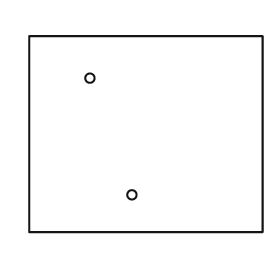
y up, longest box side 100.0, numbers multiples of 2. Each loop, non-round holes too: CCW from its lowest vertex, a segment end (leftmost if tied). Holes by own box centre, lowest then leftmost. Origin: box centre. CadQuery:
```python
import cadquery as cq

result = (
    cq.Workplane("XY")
    .moveTo(-50.0, -42.0)
    .lineTo(50.0, -42.0)
    .lineTo(50.0, 42.0)
    .lineTo(-50.0, 42.0)
    .close()
    .moveTo(-6.0, -26.0)
    .circle(2.0)
    .moveTo(-24.0, 24.0)
    .circle(2.0)
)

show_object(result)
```